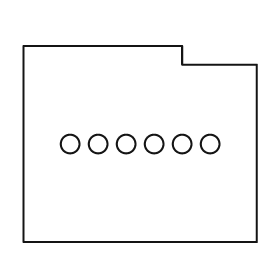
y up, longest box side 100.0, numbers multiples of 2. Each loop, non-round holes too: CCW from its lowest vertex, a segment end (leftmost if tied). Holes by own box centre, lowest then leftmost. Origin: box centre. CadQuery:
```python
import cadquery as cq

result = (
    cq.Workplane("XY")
    .moveTo(-50.0, -42.0)
    .lineTo(50.0, -42.0)
    .lineTo(50.0, 34.0)
    .lineTo(18.0, 34.0)
    .lineTo(18.0, 42.0)
    .lineTo(-50.0, 42.0)
    .close()
    .moveTo(-30.0, 0.0)
    .circle(4.0)
    .moveTo(-18.0, 0.0)
    .circle(4.0)
    .moveTo(-6.0, 0.0)
    .circle(4.0)
    .moveTo(6.0, 0.0)
    .circle(4.0)
    .moveTo(18.0, 0.0)
    .circle(4.0)
    .moveTo(30.0, 0.0)
    .circle(4.0)
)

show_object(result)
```